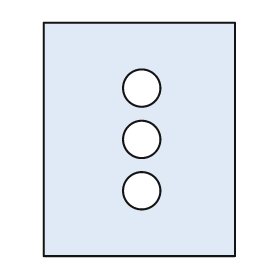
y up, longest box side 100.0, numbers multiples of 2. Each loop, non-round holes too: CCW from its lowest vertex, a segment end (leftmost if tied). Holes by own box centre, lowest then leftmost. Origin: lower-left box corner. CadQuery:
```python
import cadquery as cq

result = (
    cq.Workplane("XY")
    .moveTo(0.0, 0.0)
    .lineTo(82.0, 0.0)
    .lineTo(82.0, 100.0)
    .lineTo(0.0, 100.0)
    .close()
    .moveTo(42.0, 28.0)
    .circle(8.0)
    .moveTo(42.0, 50.0)
    .circle(8.0)
    .moveTo(42.0, 72.0)
    .circle(8.0)
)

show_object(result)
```